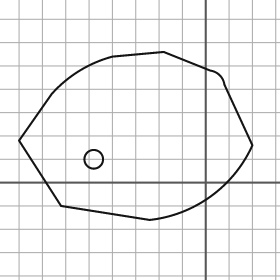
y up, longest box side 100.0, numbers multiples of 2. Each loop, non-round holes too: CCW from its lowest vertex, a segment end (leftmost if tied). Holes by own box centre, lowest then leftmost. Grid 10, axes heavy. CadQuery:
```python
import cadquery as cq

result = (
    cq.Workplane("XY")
    .moveTo(-24.0, -16.0)
    .threePointArc((2.0, -6.0), (20.0, 16.0))
    .lineTo(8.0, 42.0)
    .threePointArc((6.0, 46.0), (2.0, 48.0))
    .lineTo(-18.0, 56.0)
    .lineTo(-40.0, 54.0)
    .threePointArc((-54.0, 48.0), (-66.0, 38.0))
    .lineTo(-80.0, 18.0)
    .lineTo(-62.0, -10.0)
    .close()
    .moveTo(-48.0, 10.0)
    .circle(4.0)
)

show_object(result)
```